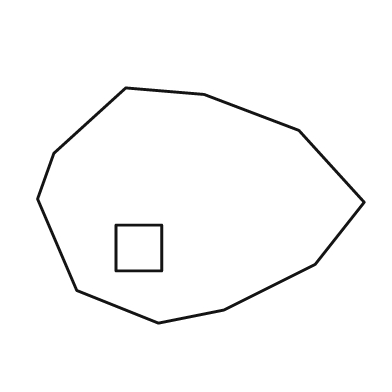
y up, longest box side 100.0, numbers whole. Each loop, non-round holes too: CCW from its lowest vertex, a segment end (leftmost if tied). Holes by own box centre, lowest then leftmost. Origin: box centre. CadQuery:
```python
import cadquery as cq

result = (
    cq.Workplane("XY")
    .moveTo(-13.0, -36.0)
    .lineTo(7.0, -32.0)
    .lineTo(35.0, -18.0)
    .lineTo(50.0, 1.0)
    .lineTo(30.0, 23.0)
    .lineTo(1.0, 34.0)
    .lineTo(-23.0, 36.0)
    .lineTo(-45.0, 16.0)
    .lineTo(-50.0, 2.0)
    .lineTo(-38.0, -26.0)
    .close()
    .moveTo(-26.0, -20.0)
    .lineTo(-12.0, -20.0)
    .lineTo(-12.0, -6.0)
    .lineTo(-26.0, -6.0)
    .close()
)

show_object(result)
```